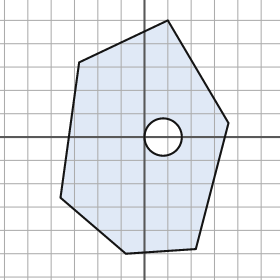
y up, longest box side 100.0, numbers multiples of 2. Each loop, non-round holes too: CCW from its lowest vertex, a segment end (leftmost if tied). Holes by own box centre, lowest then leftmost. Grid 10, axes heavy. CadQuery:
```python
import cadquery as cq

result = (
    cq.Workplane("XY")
    .moveTo(-8.0, -50.0)
    .lineTo(22.0, -48.0)
    .lineTo(36.0, 6.0)
    .lineTo(10.0, 50.0)
    .lineTo(-28.0, 32.0)
    .lineTo(-36.0, -26.0)
    .close()
    .moveTo(8.0, 0.0)
    .circle(8.0)
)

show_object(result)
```